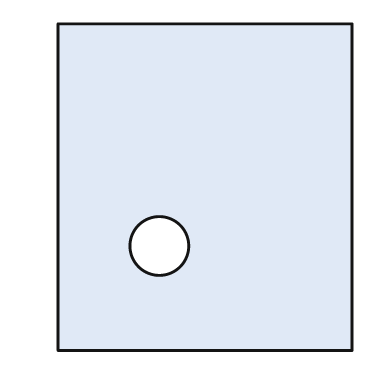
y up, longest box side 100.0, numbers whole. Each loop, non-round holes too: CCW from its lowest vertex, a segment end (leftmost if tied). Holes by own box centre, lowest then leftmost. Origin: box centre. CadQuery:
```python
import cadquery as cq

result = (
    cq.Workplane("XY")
    .moveTo(-45.0, -50.0)
    .lineTo(45.0, -50.0)
    .lineTo(45.0, 50.0)
    .lineTo(-45.0, 50.0)
    .close()
    .moveTo(-14.0, -18.0)
    .circle(9.0)
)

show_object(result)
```